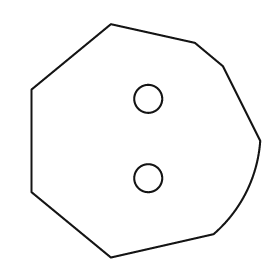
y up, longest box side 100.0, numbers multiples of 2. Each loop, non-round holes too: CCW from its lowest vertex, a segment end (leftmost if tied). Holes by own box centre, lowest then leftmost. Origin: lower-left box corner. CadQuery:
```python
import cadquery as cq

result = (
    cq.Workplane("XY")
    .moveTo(34.0, 0.0)
    .lineTo(78.0, 10.0)
    .threePointArc((92.0, 28.0), (98.0, 50.0))
    .lineTo(82.0, 82.0)
    .lineTo(70.0, 92.0)
    .lineTo(34.0, 100.0)
    .lineTo(0.0, 72.0)
    .lineTo(0.0, 28.0)
    .close()
    .moveTo(50.0, 34.0)
    .circle(6.0)
    .moveTo(50.0, 68.0)
    .circle(6.0)
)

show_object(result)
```